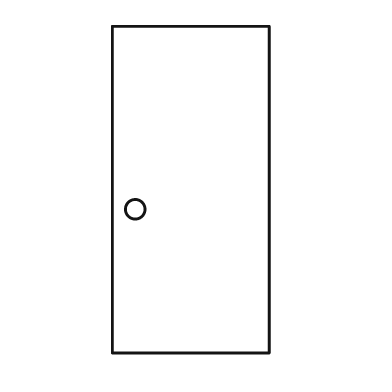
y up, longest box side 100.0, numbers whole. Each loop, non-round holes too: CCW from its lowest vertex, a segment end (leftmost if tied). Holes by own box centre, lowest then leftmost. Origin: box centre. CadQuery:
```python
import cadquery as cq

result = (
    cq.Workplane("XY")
    .moveTo(-24.0, -50.0)
    .lineTo(24.0, -50.0)
    .lineTo(24.0, 50.0)
    .lineTo(-24.0, 50.0)
    .close()
    .moveTo(-17.0, -6.0)
    .circle(3.0)
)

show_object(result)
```